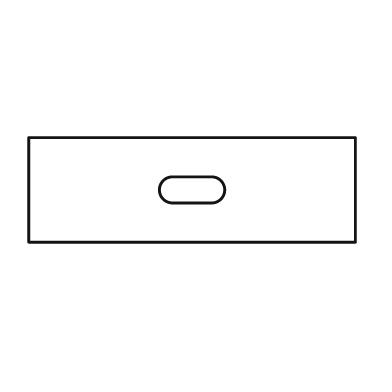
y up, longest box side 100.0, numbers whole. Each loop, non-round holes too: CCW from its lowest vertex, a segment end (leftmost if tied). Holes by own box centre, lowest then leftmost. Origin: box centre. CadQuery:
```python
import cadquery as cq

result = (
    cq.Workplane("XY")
    .moveTo(-50.0, -16.0)
    .lineTo(50.0, -16.0)
    .lineTo(50.0, 16.0)
    .lineTo(-50.0, 16.0)
    .close()
    .moveTo(-6.0, -4.0)
    .lineTo(6.0, -4.0)
    .threePointArc((10.0, 0.0), (6.0, 4.0))
    .lineTo(-6.0, 4.0)
    .threePointArc((-10.0, 0.0), (-6.0, -4.0))
    .close()
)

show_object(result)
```